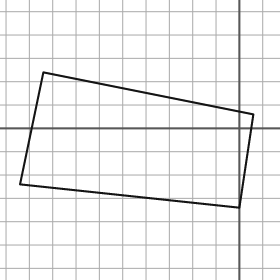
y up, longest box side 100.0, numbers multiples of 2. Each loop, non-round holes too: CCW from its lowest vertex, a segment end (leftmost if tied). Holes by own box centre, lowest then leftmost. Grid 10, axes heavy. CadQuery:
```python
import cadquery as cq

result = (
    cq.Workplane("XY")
    .moveTo(0.0, -34.0)
    .lineTo(6.0, 6.0)
    .lineTo(-84.0, 24.0)
    .lineTo(-94.0, -24.0)
    .close()
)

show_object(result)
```